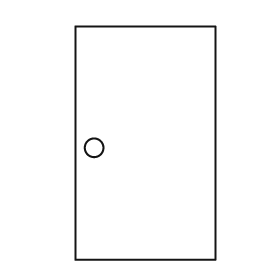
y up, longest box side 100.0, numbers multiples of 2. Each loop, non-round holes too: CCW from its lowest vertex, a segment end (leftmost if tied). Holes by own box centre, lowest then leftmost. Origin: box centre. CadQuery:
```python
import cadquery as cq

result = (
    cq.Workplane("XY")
    .moveTo(-30.0, -50.0)
    .lineTo(30.0, -50.0)
    .lineTo(30.0, 50.0)
    .lineTo(-30.0, 50.0)
    .close()
    .moveTo(-22.0, -2.0)
    .circle(4.0)
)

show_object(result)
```